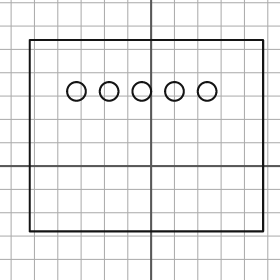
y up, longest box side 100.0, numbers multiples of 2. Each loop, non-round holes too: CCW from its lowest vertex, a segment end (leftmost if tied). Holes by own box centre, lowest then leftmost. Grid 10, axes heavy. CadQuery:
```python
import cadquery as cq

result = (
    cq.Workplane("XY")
    .moveTo(-52.0, -28.0)
    .lineTo(48.0, -28.0)
    .lineTo(48.0, 54.0)
    .lineTo(-52.0, 54.0)
    .close()
    .moveTo(-32.0, 32.0)
    .circle(4.0)
    .moveTo(-18.0, 32.0)
    .circle(4.0)
    .moveTo(-4.0, 32.0)
    .circle(4.0)
    .moveTo(10.0, 32.0)
    .circle(4.0)
    .moveTo(24.0, 32.0)
    .circle(4.0)
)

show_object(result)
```